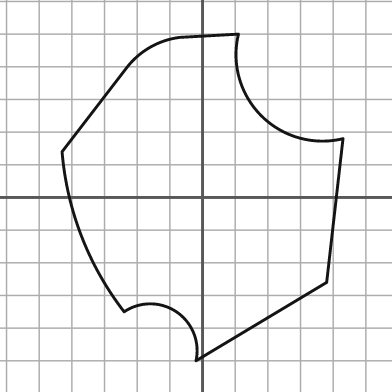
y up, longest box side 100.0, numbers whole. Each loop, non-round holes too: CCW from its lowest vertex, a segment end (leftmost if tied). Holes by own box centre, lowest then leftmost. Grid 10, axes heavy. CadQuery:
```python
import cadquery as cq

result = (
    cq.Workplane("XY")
    .moveTo(-2.0, -50.0)
    .lineTo(38.0, -26.0)
    .lineTo(43.0, 18.0)
    .threePointArc((18.0, 25.0), (11.0, 50.0))
    .lineTo(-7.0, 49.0)
    .threePointArc((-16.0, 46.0), (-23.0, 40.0))
    .lineTo(-43.0, 14.0)
    .threePointArc((-37.0, -12.0), (-24.0, -35.0))
    .threePointArc((-8.0, -35.0), (-2.0, -50.0))
    .close()
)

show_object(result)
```